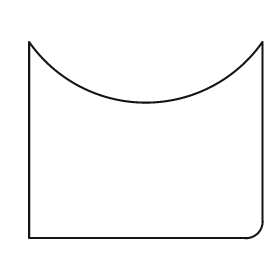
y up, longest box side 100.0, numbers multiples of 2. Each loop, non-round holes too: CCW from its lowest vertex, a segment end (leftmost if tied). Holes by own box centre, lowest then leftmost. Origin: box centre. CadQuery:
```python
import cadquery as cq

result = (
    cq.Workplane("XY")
    .moveTo(-50.0, -42.0)
    .lineTo(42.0, -42.0)
    .threePointArc((48.0, -40.0), (50.0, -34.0))
    .lineTo(50.0, 42.0)
    .threePointArc((0.0, 16.0), (-50.0, 42.0))
    .close()
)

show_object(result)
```